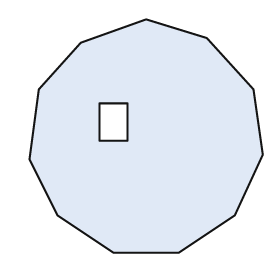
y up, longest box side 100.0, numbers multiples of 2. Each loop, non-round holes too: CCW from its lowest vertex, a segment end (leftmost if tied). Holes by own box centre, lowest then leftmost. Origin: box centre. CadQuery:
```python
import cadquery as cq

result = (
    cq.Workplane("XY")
    .moveTo(-14.0, -50.0)
    .lineTo(14.0, -50.0)
    .lineTo(38.0, -34.0)
    .lineTo(50.0, -8.0)
    .lineTo(46.0, 20.0)
    .lineTo(26.0, 42.0)
    .lineTo(0.0, 50.0)
    .lineTo(-28.0, 40.0)
    .lineTo(-46.0, 20.0)
    .lineTo(-50.0, -10.0)
    .lineTo(-38.0, -34.0)
    .close()
    .moveTo(-20.0, -2.0)
    .lineTo(-8.0, -2.0)
    .lineTo(-8.0, 14.0)
    .lineTo(-20.0, 14.0)
    .close()
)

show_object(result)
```